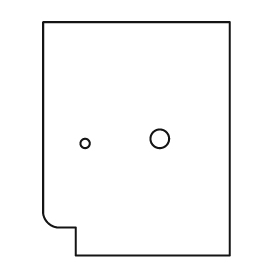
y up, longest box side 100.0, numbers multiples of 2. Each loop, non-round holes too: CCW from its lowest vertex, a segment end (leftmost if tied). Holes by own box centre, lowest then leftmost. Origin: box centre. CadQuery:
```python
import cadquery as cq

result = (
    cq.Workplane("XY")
    .moveTo(-26.0, -50.0)
    .lineTo(40.0, -50.0)
    .lineTo(40.0, 50.0)
    .lineTo(-40.0, 50.0)
    .lineTo(-40.0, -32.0)
    .threePointArc((-38.0, -36.0), (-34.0, -38.0))
    .lineTo(-26.0, -38.0)
    .close()
    .moveTo(-22.0, -2.0)
    .circle(2.0)
    .moveTo(10.0, 0.0)
    .circle(4.0)
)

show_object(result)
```